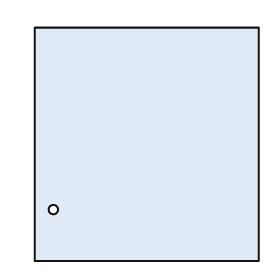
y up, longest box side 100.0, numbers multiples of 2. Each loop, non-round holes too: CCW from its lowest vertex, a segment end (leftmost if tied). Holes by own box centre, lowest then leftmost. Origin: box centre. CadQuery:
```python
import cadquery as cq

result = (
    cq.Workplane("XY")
    .moveTo(-48.0, -50.0)
    .lineTo(48.0, -50.0)
    .lineTo(48.0, 50.0)
    .lineTo(-48.0, 50.0)
    .close()
    .moveTo(-40.0, -28.0)
    .circle(2.0)
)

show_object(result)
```